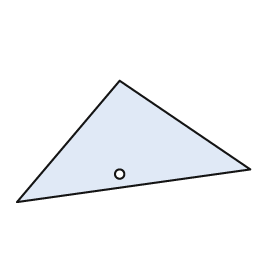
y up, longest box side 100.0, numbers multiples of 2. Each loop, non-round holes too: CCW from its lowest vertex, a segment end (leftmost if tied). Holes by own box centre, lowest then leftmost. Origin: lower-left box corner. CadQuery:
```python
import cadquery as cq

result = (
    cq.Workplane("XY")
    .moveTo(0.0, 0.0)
    .lineTo(100.0, 14.0)
    .lineTo(44.0, 52.0)
    .close()
    .moveTo(44.0, 12.0)
    .circle(2.0)
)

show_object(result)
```